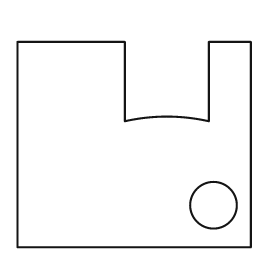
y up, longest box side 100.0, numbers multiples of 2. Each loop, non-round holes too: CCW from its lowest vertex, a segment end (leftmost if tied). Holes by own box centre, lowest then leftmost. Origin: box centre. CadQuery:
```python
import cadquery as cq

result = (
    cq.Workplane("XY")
    .moveTo(-50.0, -44.0)
    .lineTo(50.0, -44.0)
    .lineTo(50.0, 44.0)
    .lineTo(32.0, 44.0)
    .lineTo(32.0, 10.0)
    .threePointArc((14.0, 12.0), (-4.0, 10.0))
    .lineTo(-4.0, 44.0)
    .lineTo(-50.0, 44.0)
    .close()
    .moveTo(34.0, -26.0)
    .circle(10.0)
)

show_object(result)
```